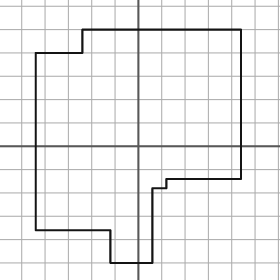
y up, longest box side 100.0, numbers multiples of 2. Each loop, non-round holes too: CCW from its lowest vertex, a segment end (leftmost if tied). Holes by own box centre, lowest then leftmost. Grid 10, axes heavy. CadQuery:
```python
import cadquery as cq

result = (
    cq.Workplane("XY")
    .moveTo(-12.0, -50.0)
    .lineTo(6.0, -50.0)
    .lineTo(6.0, -18.0)
    .lineTo(12.0, -18.0)
    .lineTo(12.0, -14.0)
    .lineTo(44.0, -14.0)
    .lineTo(44.0, 50.0)
    .lineTo(-24.0, 50.0)
    .lineTo(-24.0, 40.0)
    .lineTo(-44.0, 40.0)
    .lineTo(-44.0, -36.0)
    .lineTo(-12.0, -36.0)
    .close()
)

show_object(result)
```